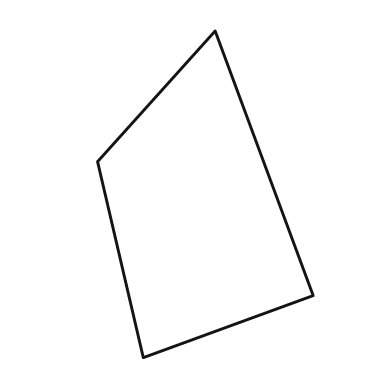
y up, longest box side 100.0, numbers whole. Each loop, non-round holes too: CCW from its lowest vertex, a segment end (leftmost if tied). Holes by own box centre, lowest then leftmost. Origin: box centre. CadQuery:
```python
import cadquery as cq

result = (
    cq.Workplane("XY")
    .moveTo(-19.0, -50.0)
    .lineTo(33.0, -31.0)
    .lineTo(3.0, 50.0)
    .lineTo(-33.0, 10.0)
    .close()
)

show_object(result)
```